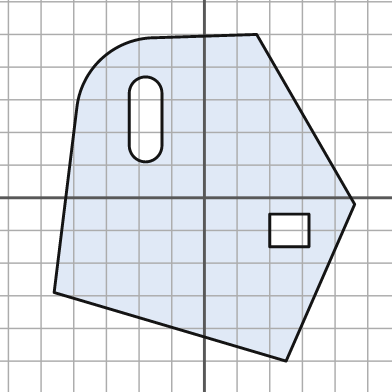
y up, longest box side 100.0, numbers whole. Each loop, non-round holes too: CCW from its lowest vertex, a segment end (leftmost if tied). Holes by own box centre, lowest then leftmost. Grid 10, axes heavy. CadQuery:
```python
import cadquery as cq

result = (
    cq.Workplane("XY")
    .moveTo(25.0, -50.0)
    .lineTo(46.0, -2.0)
    .lineTo(16.0, 50.0)
    .lineTo(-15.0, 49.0)
    .threePointArc((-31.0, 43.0), (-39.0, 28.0))
    .lineTo(-46.0, -29.0)
    .close()
    .moveTo(20.0, -15.0)
    .lineTo(32.0, -15.0)
    .lineTo(32.0, -5.0)
    .lineTo(20.0, -5.0)
    .close()
    .moveTo(-23.0, 16.0)
    .threePointArc((-18.0, 11.0), (-13.0, 16.0))
    .lineTo(-13.0, 32.0)
    .threePointArc((-18.0, 37.0), (-23.0, 32.0))
    .close()
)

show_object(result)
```